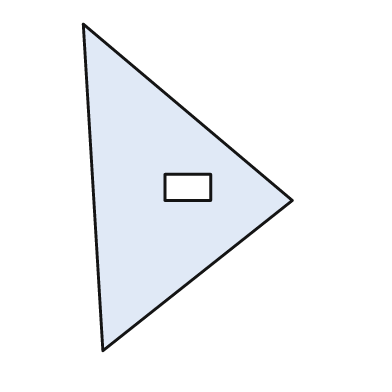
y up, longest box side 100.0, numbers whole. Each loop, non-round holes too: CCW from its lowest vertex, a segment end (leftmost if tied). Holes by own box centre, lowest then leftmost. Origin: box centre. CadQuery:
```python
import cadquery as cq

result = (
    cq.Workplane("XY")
    .moveTo(-26.0, -50.0)
    .lineTo(32.0, -4.0)
    .lineTo(-32.0, 50.0)
    .close()
    .moveTo(-7.0, -4.0)
    .lineTo(7.0, -4.0)
    .lineTo(7.0, 4.0)
    .lineTo(-7.0, 4.0)
    .close()
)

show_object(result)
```